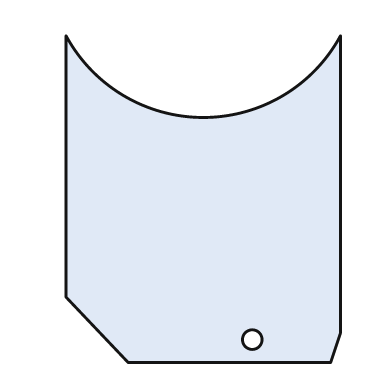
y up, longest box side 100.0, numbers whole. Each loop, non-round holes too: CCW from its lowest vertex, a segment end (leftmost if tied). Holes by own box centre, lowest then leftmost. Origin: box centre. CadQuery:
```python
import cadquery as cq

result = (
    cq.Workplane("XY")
    .moveTo(-23.0, -50.0)
    .lineTo(39.0, -50.0)
    .lineTo(42.0, -41.0)
    .lineTo(42.0, 50.0)
    .threePointArc((0.0, 25.0), (-42.0, 50.0))
    .lineTo(-42.0, -30.0)
    .close()
    .moveTo(15.0, -43.0)
    .circle(3.0)
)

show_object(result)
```